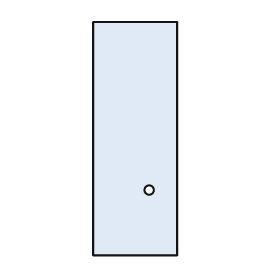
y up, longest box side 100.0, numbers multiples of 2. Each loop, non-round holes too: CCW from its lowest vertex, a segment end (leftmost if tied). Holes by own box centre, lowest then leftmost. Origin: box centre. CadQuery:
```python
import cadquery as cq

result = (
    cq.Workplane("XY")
    .moveTo(-18.0, -50.0)
    .lineTo(18.0, -50.0)
    .lineTo(18.0, 50.0)
    .lineTo(-18.0, 50.0)
    .close()
    .moveTo(6.0, -22.0)
    .circle(2.0)
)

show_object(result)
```